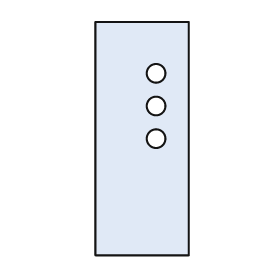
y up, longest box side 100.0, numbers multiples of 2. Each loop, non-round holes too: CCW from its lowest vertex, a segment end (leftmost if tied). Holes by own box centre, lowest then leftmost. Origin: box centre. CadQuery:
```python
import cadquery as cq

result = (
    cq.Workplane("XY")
    .moveTo(-20.0, -50.0)
    .lineTo(20.0, -50.0)
    .lineTo(20.0, 50.0)
    .lineTo(-20.0, 50.0)
    .close()
    .moveTo(6.0, 0.0)
    .circle(4.0)
    .moveTo(6.0, 14.0)
    .circle(4.0)
    .moveTo(6.0, 28.0)
    .circle(4.0)
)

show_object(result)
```